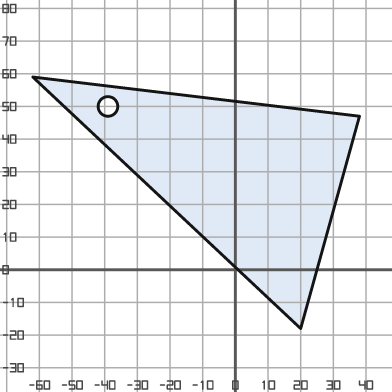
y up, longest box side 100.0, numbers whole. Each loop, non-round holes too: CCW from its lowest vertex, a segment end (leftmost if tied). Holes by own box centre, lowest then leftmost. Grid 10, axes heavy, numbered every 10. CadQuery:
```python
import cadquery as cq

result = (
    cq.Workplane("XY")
    .moveTo(20.0, -18.0)
    .lineTo(38.0, 47.0)
    .lineTo(-62.0, 59.0)
    .close()
    .moveTo(-39.0, 50.0)
    .circle(3.0)
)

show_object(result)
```